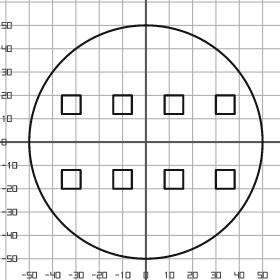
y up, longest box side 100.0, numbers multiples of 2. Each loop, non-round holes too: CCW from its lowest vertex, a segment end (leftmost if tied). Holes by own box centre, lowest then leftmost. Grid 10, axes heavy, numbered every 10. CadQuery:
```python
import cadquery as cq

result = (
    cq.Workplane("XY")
    .moveTo(0.0, 0.0)
    .circle(50.0)
    .moveTo(-36.0, -20.0)
    .lineTo(-28.0, -20.0)
    .lineTo(-28.0, -12.0)
    .lineTo(-36.0, -12.0)
    .close()
    .moveTo(-14.0, -20.0)
    .lineTo(-6.0, -20.0)
    .lineTo(-6.0, -12.0)
    .lineTo(-14.0, -12.0)
    .close()
    .moveTo(8.0, -20.0)
    .lineTo(16.0, -20.0)
    .lineTo(16.0, -12.0)
    .lineTo(8.0, -12.0)
    .close()
    .moveTo(30.0, -20.0)
    .lineTo(38.0, -20.0)
    .lineTo(38.0, -12.0)
    .lineTo(30.0, -12.0)
    .close()
    .moveTo(-36.0, 12.0)
    .lineTo(-28.0, 12.0)
    .lineTo(-28.0, 20.0)
    .lineTo(-36.0, 20.0)
    .close()
    .moveTo(-14.0, 12.0)
    .lineTo(-6.0, 12.0)
    .lineTo(-6.0, 20.0)
    .lineTo(-14.0, 20.0)
    .close()
    .moveTo(8.0, 12.0)
    .lineTo(16.0, 12.0)
    .lineTo(16.0, 20.0)
    .lineTo(8.0, 20.0)
    .close()
    .moveTo(30.0, 12.0)
    .lineTo(38.0, 12.0)
    .lineTo(38.0, 20.0)
    .lineTo(30.0, 20.0)
    .close()
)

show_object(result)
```